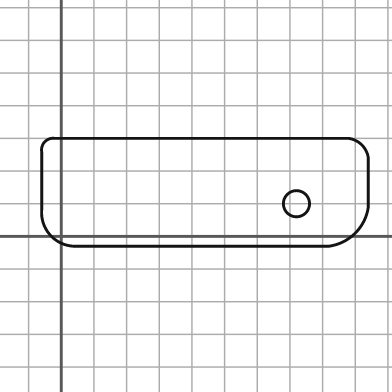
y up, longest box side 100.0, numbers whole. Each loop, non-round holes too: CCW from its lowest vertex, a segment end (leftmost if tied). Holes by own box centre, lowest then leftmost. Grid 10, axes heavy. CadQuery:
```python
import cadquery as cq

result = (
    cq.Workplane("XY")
    .moveTo(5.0, -3.0)
    .lineTo(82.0, -3.0)
    .threePointArc((90.0, 1.0), (94.0, 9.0))
    .lineTo(94.0, 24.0)
    .threePointArc((92.0, 28.0), (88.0, 30.0))
    .lineTo(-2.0, 30.0)
    .threePointArc((-5.0, 29.0), (-6.0, 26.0))
    .lineTo(-6.0, 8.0)
    .threePointArc((-3.0, 0.0), (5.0, -3.0))
    .close()
    .moveTo(72.0, 10.0)
    .circle(4.0)
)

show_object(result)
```